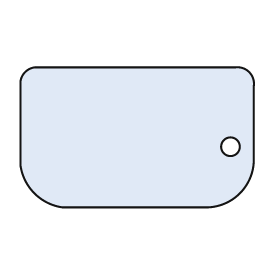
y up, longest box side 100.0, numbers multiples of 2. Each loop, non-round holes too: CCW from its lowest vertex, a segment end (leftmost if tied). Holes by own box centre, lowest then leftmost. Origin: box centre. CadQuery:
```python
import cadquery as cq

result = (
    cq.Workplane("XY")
    .moveTo(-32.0, -30.0)
    .lineTo(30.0, -30.0)
    .threePointArc((44.0, -24.0), (50.0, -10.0))
    .lineTo(50.0, 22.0)
    .threePointArc((48.0, 28.0), (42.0, 30.0))
    .lineTo(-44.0, 30.0)
    .threePointArc((-48.0, 28.0), (-50.0, 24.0))
    .lineTo(-50.0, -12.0)
    .threePointArc((-44.0, -24.0), (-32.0, -30.0))
    .close()
    .moveTo(40.0, -4.0)
    .circle(4.0)
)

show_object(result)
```